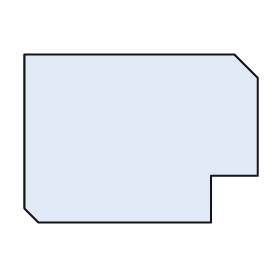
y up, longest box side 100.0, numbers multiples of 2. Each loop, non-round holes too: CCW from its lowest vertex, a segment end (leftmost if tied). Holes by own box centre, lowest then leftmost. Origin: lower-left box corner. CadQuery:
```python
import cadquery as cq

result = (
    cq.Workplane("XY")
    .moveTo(6.0, 0.0)
    .lineTo(80.0, 0.0)
    .lineTo(80.0, 20.0)
    .lineTo(100.0, 20.0)
    .lineTo(100.0, 62.0)
    .lineTo(90.0, 72.0)
    .lineTo(0.0, 72.0)
    .lineTo(0.0, 6.0)
    .close()
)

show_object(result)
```